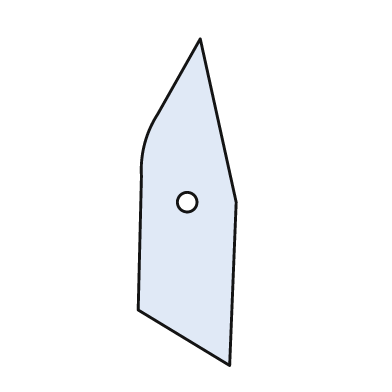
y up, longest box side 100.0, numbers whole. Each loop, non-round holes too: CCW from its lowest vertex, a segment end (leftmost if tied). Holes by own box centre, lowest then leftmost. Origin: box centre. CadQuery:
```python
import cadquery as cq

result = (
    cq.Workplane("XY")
    .moveTo(13.0, -50.0)
    .lineTo(15.0, 0.0)
    .lineTo(4.0, 50.0)
    .lineTo(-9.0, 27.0)
    .threePointArc((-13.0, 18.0), (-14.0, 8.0))
    .lineTo(-15.0, -33.0)
    .close()
    .moveTo(0.0, 0.0)
    .circle(3.0)
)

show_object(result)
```